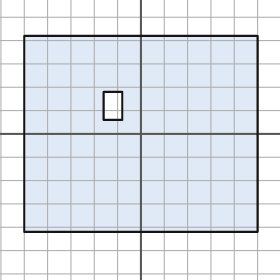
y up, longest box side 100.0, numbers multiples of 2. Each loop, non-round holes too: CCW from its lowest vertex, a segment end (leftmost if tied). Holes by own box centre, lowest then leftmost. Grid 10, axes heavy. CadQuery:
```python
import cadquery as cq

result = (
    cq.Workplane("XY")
    .moveTo(-50.0, -42.0)
    .lineTo(50.0, -42.0)
    .lineTo(50.0, 42.0)
    .lineTo(-50.0, 42.0)
    .close()
    .moveTo(-16.0, 6.0)
    .lineTo(-8.0, 6.0)
    .lineTo(-8.0, 18.0)
    .lineTo(-16.0, 18.0)
    .close()
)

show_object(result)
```